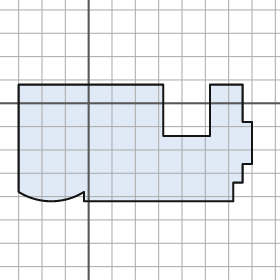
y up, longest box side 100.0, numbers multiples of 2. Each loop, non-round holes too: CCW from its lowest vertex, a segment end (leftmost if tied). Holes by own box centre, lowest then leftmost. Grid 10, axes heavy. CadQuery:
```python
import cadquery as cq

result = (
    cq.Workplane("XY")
    .moveTo(-2.0, -42.0)
    .lineTo(62.0, -42.0)
    .lineTo(62.0, -34.0)
    .lineTo(66.0, -34.0)
    .lineTo(66.0, -26.0)
    .lineTo(70.0, -26.0)
    .lineTo(70.0, -8.0)
    .lineTo(66.0, -8.0)
    .lineTo(66.0, 8.0)
    .lineTo(52.0, 8.0)
    .lineTo(52.0, -14.0)
    .lineTo(32.0, -14.0)
    .lineTo(32.0, 8.0)
    .lineTo(-30.0, 8.0)
    .lineTo(-30.0, -38.0)
    .threePointArc((-16.0, -42.0), (-2.0, -38.0))
    .close()
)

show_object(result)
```